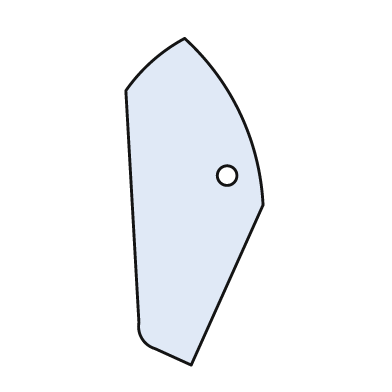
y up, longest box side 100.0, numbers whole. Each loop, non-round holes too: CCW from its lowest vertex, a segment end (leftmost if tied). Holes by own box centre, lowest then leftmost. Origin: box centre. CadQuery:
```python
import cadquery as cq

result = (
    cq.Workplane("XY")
    .moveTo(-1.0, -50.0)
    .lineTo(21.0, -1.0)
    .threePointArc((14.0, 27.0), (-3.0, 50.0))
    .threePointArc((-13.0, 43.0), (-21.0, 34.0))
    .lineTo(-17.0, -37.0)
    .threePointArc((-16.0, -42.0), (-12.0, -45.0))
    .close()
    .moveTo(10.0, 8.0)
    .circle(3.0)
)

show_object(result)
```